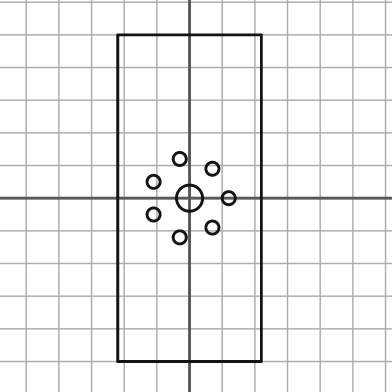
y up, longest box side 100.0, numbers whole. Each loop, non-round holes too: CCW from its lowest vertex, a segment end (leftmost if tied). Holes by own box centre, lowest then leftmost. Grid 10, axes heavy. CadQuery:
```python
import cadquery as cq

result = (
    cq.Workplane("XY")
    .moveTo(-22.0, -50.0)
    .lineTo(22.0, -50.0)
    .lineTo(22.0, 50.0)
    .lineTo(-22.0, 50.0)
    .close()
    .moveTo(-3.0, -12.0)
    .circle(2.0)
    .moveTo(7.0, -9.0)
    .circle(2.0)
    .moveTo(-11.0, -5.0)
    .circle(2.0)
    .moveTo(0.0, 0.0)
    .circle(4.0)
    .moveTo(12.0, 0.0)
    .circle(2.0)
    .moveTo(-11.0, 5.0)
    .circle(2.0)
    .moveTo(7.0, 9.0)
    .circle(2.0)
    .moveTo(-3.0, 12.0)
    .circle(2.0)
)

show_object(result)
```